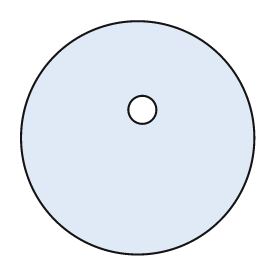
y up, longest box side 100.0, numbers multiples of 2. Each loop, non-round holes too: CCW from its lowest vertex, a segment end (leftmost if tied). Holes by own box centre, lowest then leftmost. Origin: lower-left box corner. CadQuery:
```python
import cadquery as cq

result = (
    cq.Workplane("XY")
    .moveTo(50.0, 50.0)
    .circle(50.0)
    .moveTo(52.0, 62.0)
    .circle(6.0)
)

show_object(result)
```